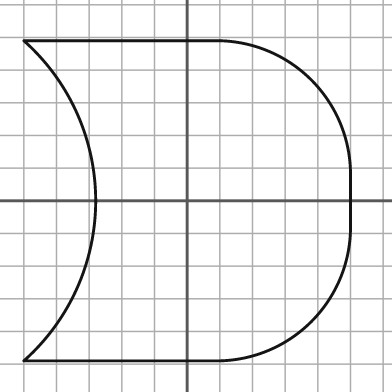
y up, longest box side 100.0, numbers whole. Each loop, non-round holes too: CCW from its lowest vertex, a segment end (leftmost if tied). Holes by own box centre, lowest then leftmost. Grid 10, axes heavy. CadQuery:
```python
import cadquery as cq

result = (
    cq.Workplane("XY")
    .moveTo(-50.0, -49.0)
    .lineTo(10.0, -49.0)
    .threePointArc((38.0, -37.0), (50.0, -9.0))
    .lineTo(50.0, 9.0)
    .threePointArc((38.0, 37.0), (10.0, 49.0))
    .lineTo(-50.0, 49.0)
    .threePointArc((-28.0, 0.0), (-50.0, -49.0))
    .close()
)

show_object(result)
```